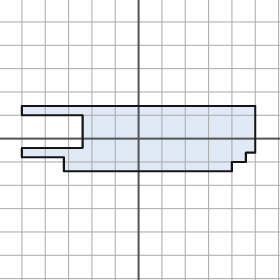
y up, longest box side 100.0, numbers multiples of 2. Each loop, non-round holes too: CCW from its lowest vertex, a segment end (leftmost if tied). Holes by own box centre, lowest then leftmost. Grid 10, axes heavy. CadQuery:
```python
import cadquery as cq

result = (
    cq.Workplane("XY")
    .moveTo(-32.0, -14.0)
    .lineTo(40.0, -14.0)
    .lineTo(40.0, -10.0)
    .lineTo(46.0, -10.0)
    .lineTo(46.0, -6.0)
    .lineTo(50.0, -6.0)
    .lineTo(50.0, 14.0)
    .lineTo(-50.0, 14.0)
    .lineTo(-50.0, 10.0)
    .lineTo(-24.0, 10.0)
    .lineTo(-24.0, -4.0)
    .lineTo(-50.0, -4.0)
    .lineTo(-50.0, -8.0)
    .lineTo(-32.0, -8.0)
    .close()
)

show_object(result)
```